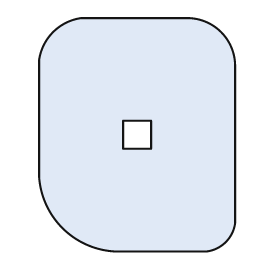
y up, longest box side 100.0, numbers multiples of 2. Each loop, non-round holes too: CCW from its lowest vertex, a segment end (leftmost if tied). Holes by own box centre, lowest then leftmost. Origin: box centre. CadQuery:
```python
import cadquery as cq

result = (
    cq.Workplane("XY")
    .moveTo(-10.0, -50.0)
    .lineTo(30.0, -50.0)
    .threePointArc((38.0, -46.0), (42.0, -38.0))
    .lineTo(42.0, 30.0)
    .threePointArc((36.0, 44.0), (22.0, 50.0))
    .lineTo(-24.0, 50.0)
    .threePointArc((-36.0, 44.0), (-42.0, 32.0))
    .lineTo(-42.0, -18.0)
    .threePointArc((-32.0, -40.0), (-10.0, -50.0))
    .close()
    .moveTo(-6.0, -6.0)
    .lineTo(6.0, -6.0)
    .lineTo(6.0, 6.0)
    .lineTo(-6.0, 6.0)
    .close()
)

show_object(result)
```